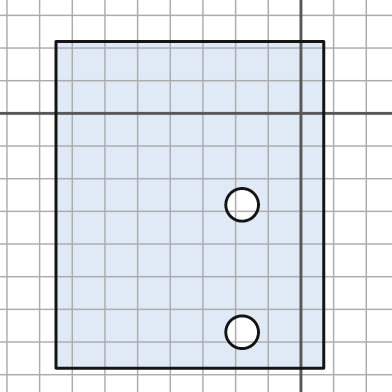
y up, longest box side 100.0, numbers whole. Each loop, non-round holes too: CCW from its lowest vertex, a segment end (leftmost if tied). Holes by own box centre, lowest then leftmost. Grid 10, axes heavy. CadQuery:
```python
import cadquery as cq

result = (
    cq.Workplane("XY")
    .moveTo(-75.0, -78.0)
    .lineTo(7.0, -78.0)
    .lineTo(7.0, 22.0)
    .lineTo(-75.0, 22.0)
    .close()
    .moveTo(-18.0, -67.0)
    .circle(5.0)
    .moveTo(-18.0, -28.0)
    .circle(5.0)
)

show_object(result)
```